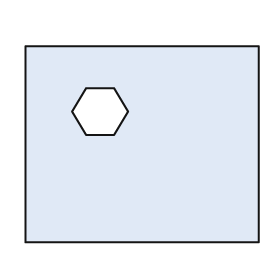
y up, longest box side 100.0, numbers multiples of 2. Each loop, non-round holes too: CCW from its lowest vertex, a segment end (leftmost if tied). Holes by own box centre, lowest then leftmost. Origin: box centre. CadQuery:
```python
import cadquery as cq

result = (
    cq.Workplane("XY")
    .moveTo(-50.0, -42.0)
    .lineTo(50.0, -42.0)
    .lineTo(50.0, 42.0)
    .lineTo(-50.0, 42.0)
    .close()
    .moveTo(-24.0, 4.0)
    .lineTo(-12.0, 4.0)
    .lineTo(-6.0, 14.0)
    .lineTo(-12.0, 24.0)
    .lineTo(-24.0, 24.0)
    .lineTo(-30.0, 14.0)
    .close()
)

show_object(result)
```